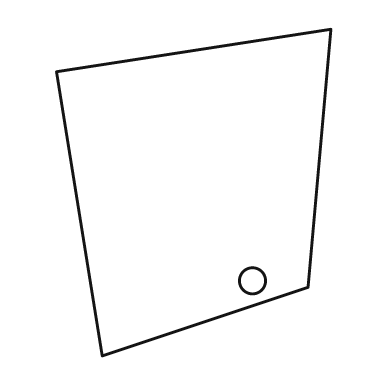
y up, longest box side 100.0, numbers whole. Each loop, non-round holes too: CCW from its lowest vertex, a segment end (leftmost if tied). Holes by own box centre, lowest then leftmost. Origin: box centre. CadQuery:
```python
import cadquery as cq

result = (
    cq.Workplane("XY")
    .moveTo(-28.0, -50.0)
    .lineTo(35.0, -29.0)
    .lineTo(42.0, 50.0)
    .lineTo(-42.0, 37.0)
    .close()
    .moveTo(18.0, -27.0)
    .circle(4.0)
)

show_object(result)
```